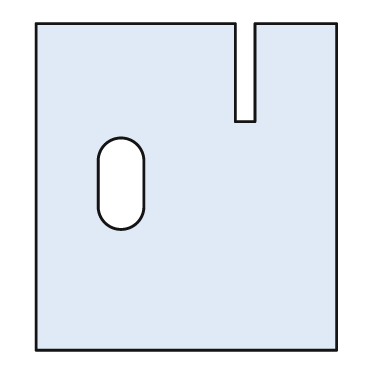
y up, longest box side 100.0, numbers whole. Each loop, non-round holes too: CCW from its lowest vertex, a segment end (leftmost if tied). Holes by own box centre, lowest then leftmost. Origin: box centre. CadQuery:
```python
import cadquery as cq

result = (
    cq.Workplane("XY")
    .moveTo(-46.0, -50.0)
    .lineTo(46.0, -50.0)
    .lineTo(46.0, 50.0)
    .lineTo(21.0, 50.0)
    .lineTo(21.0, 20.0)
    .lineTo(15.0, 20.0)
    .lineTo(15.0, 50.0)
    .lineTo(-46.0, 50.0)
    .close()
    .moveTo(-27.0, -6.0)
    .threePointArc((-20.0, -13.0), (-13.0, -6.0))
    .lineTo(-13.0, 8.0)
    .threePointArc((-20.0, 15.0), (-27.0, 8.0))
    .close()
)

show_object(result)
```